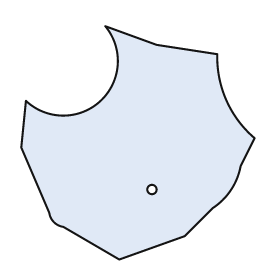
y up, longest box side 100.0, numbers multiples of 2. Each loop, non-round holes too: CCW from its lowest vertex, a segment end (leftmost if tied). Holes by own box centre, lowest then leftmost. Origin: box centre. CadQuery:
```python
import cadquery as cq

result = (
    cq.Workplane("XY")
    .moveTo(-8.0, -50.0)
    .lineTo(20.0, -40.0)
    .lineTo(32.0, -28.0)
    .threePointArc((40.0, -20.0), (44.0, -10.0))
    .lineTo(50.0, 2.0)
    .threePointArc((38.0, 18.0), (34.0, 38.0))
    .lineTo(8.0, 42.0)
    .lineTo(-14.0, 50.0)
    .threePointArc((-16.0, 18.0), (-48.0, 18.0))
    .lineTo(-50.0, -2.0)
    .lineTo(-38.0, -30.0)
    .threePointArc((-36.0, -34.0), (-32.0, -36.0))
    .close()
    .moveTo(6.0, -20.0)
    .circle(2.0)
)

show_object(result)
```